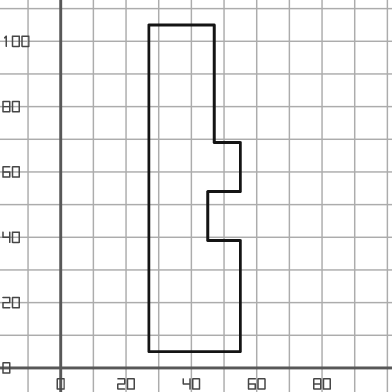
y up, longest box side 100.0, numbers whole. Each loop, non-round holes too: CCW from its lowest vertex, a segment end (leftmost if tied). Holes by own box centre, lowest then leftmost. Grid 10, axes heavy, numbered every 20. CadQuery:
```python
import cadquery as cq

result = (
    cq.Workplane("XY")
    .moveTo(27.0, 5.0)
    .lineTo(55.0, 5.0)
    .lineTo(55.0, 39.0)
    .lineTo(45.0, 39.0)
    .lineTo(45.0, 54.0)
    .lineTo(55.0, 54.0)
    .lineTo(55.0, 69.0)
    .lineTo(47.0, 69.0)
    .lineTo(47.0, 105.0)
    .lineTo(27.0, 105.0)
    .close()
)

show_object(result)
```